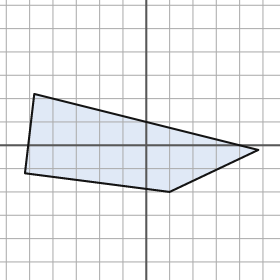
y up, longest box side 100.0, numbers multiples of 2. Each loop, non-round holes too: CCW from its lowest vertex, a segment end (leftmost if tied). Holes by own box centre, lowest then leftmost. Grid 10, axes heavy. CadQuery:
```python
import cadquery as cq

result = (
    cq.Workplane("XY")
    .moveTo(10.0, -20.0)
    .lineTo(48.0, -2.0)
    .lineTo(-48.0, 22.0)
    .lineTo(-52.0, -12.0)
    .close()
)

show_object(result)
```